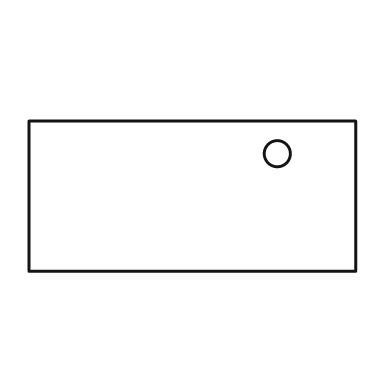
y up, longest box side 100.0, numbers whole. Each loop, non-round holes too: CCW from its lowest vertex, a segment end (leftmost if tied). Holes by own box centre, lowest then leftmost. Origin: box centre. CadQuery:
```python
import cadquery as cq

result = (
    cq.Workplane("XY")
    .moveTo(-50.0, -23.0)
    .lineTo(50.0, -23.0)
    .lineTo(50.0, 23.0)
    .lineTo(-50.0, 23.0)
    .close()
    .moveTo(26.0, 13.0)
    .circle(4.0)
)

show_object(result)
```